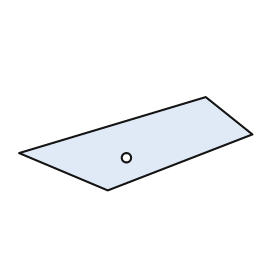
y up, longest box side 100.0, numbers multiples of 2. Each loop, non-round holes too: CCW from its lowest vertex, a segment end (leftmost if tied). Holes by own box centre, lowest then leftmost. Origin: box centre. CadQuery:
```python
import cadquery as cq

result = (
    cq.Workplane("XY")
    .moveTo(-12.0, -20.0)
    .lineTo(50.0, 4.0)
    .lineTo(30.0, 20.0)
    .lineTo(-50.0, -4.0)
    .close()
    .moveTo(-4.0, -6.0)
    .circle(2.0)
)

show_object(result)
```